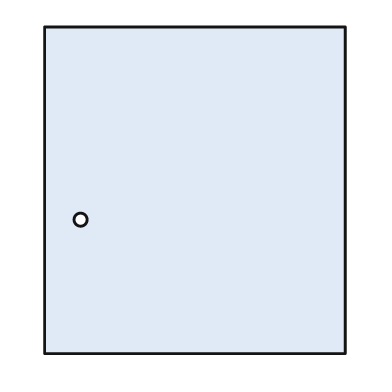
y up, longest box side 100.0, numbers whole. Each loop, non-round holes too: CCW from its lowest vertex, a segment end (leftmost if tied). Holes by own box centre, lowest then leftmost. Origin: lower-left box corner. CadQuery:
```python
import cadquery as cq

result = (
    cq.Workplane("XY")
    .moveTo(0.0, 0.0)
    .lineTo(92.0, 0.0)
    .lineTo(92.0, 100.0)
    .lineTo(0.0, 100.0)
    .close()
    .moveTo(11.0, 41.0)
    .circle(2.0)
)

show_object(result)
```